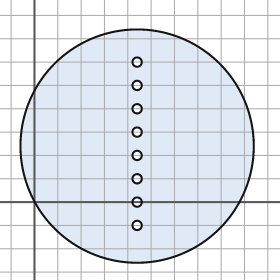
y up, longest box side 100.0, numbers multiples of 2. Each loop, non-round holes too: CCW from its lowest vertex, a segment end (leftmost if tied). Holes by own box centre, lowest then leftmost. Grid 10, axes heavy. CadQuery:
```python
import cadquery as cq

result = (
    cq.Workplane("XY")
    .moveTo(44.0, 24.0)
    .circle(50.0)
    .moveTo(44.0, -10.0)
    .circle(2.0)
    .moveTo(44.0, 0.0)
    .circle(2.0)
    .moveTo(44.0, 10.0)
    .circle(2.0)
    .moveTo(44.0, 20.0)
    .circle(2.0)
    .moveTo(44.0, 30.0)
    .circle(2.0)
    .moveTo(44.0, 40.0)
    .circle(2.0)
    .moveTo(44.0, 50.0)
    .circle(2.0)
    .moveTo(44.0, 60.0)
    .circle(2.0)
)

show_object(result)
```